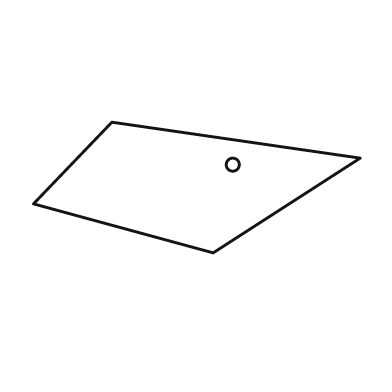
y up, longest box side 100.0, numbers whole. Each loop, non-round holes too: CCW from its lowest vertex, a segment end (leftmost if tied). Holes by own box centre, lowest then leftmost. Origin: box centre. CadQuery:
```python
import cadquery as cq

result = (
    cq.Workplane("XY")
    .moveTo(5.0, -20.0)
    .lineTo(50.0, 9.0)
    .lineTo(-26.0, 20.0)
    .lineTo(-50.0, -5.0)
    .close()
    .moveTo(11.0, 7.0)
    .circle(2.0)
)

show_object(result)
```